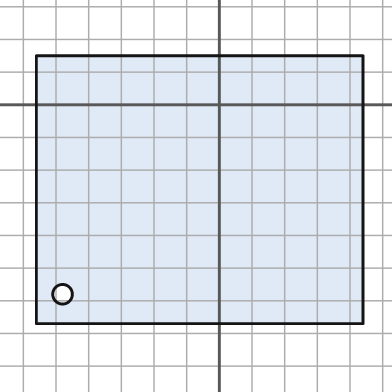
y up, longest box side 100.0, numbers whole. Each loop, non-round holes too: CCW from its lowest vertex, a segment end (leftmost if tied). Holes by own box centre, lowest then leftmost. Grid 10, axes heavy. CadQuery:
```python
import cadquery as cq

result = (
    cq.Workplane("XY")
    .moveTo(-56.0, -67.0)
    .lineTo(44.0, -67.0)
    .lineTo(44.0, 15.0)
    .lineTo(-56.0, 15.0)
    .close()
    .moveTo(-48.0, -58.0)
    .circle(3.0)
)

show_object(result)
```